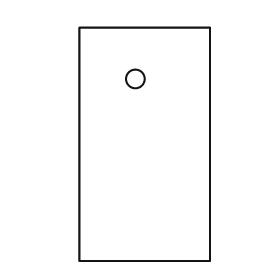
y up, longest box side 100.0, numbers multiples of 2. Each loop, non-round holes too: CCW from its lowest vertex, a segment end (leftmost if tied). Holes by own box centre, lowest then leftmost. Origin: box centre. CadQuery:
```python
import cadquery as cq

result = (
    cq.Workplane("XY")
    .moveTo(-28.0, -50.0)
    .lineTo(28.0, -50.0)
    .lineTo(28.0, 50.0)
    .lineTo(-28.0, 50.0)
    .close()
    .moveTo(-4.0, 28.0)
    .circle(4.0)
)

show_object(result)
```